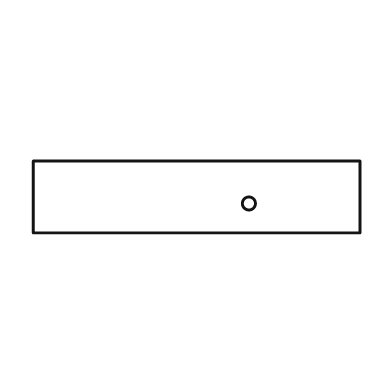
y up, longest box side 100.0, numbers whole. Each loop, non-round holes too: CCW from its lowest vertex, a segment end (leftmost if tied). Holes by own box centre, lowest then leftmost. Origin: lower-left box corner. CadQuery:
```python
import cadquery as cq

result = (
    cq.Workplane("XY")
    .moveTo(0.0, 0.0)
    .lineTo(100.0, 0.0)
    .lineTo(100.0, 22.0)
    .lineTo(0.0, 22.0)
    .close()
    .moveTo(66.0, 9.0)
    .circle(2.0)
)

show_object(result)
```